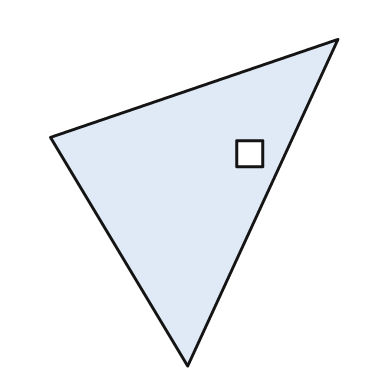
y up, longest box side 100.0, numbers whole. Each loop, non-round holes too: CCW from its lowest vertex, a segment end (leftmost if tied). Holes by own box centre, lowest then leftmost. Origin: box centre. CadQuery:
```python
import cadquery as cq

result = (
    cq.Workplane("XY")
    .moveTo(-2.0, -50.0)
    .lineTo(44.0, 50.0)
    .lineTo(-44.0, 20.0)
    .close()
    .moveTo(13.0, 11.0)
    .lineTo(21.0, 11.0)
    .lineTo(21.0, 19.0)
    .lineTo(13.0, 19.0)
    .close()
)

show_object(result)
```